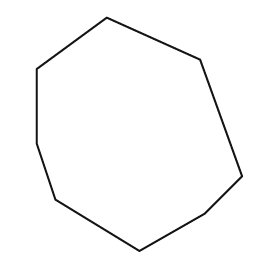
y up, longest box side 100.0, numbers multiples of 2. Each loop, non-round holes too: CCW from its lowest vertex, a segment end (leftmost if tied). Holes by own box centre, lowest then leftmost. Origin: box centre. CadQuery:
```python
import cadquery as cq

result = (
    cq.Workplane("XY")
    .moveTo(0.0, -50.0)
    .lineTo(28.0, -34.0)
    .lineTo(44.0, -18.0)
    .lineTo(26.0, 32.0)
    .lineTo(-14.0, 50.0)
    .lineTo(-44.0, 28.0)
    .lineTo(-44.0, -4.0)
    .lineTo(-36.0, -28.0)
    .close()
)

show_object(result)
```